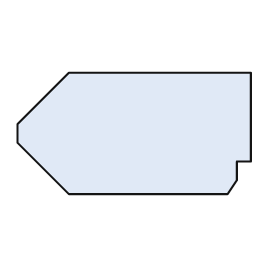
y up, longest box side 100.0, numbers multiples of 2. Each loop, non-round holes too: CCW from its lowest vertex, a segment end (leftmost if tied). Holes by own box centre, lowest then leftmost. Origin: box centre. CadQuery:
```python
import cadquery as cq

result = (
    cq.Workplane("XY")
    .moveTo(-28.0, -26.0)
    .lineTo(40.0, -26.0)
    .lineTo(44.0, -20.0)
    .lineTo(44.0, -12.0)
    .lineTo(50.0, -12.0)
    .lineTo(50.0, 26.0)
    .lineTo(-28.0, 26.0)
    .lineTo(-50.0, 4.0)
    .lineTo(-50.0, -4.0)
    .close()
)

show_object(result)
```